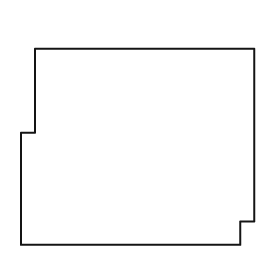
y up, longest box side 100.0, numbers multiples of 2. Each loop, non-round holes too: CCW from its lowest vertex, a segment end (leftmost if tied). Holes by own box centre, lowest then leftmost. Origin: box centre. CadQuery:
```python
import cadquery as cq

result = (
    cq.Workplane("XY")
    .moveTo(-50.0, -42.0)
    .lineTo(44.0, -42.0)
    .lineTo(44.0, -32.0)
    .lineTo(50.0, -32.0)
    .lineTo(50.0, 42.0)
    .lineTo(-44.0, 42.0)
    .lineTo(-44.0, 6.0)
    .lineTo(-50.0, 6.0)
    .close()
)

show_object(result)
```